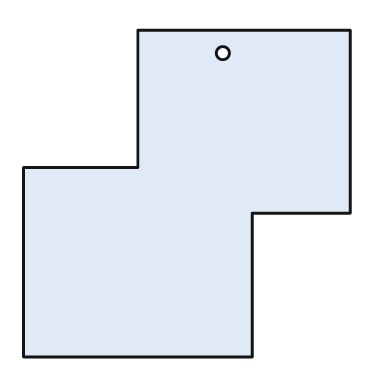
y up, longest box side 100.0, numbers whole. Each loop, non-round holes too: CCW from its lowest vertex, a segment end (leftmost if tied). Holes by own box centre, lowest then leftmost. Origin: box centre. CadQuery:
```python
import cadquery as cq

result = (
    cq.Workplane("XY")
    .moveTo(-50.0, -50.0)
    .lineTo(20.0, -50.0)
    .lineTo(20.0, -6.0)
    .lineTo(50.0, -6.0)
    .lineTo(50.0, 50.0)
    .lineTo(-15.0, 50.0)
    .lineTo(-15.0, 8.0)
    .lineTo(-50.0, 8.0)
    .close()
    .moveTo(11.0, 43.0)
    .circle(2.0)
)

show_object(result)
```